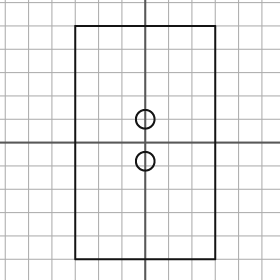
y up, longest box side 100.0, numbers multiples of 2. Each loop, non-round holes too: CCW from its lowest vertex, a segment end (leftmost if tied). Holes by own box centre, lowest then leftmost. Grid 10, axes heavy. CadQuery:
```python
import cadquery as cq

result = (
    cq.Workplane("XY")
    .moveTo(-30.0, -50.0)
    .lineTo(30.0, -50.0)
    .lineTo(30.0, 50.0)
    .lineTo(-30.0, 50.0)
    .close()
    .moveTo(0.0, -8.0)
    .circle(4.0)
    .moveTo(0.0, 10.0)
    .circle(4.0)
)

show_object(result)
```